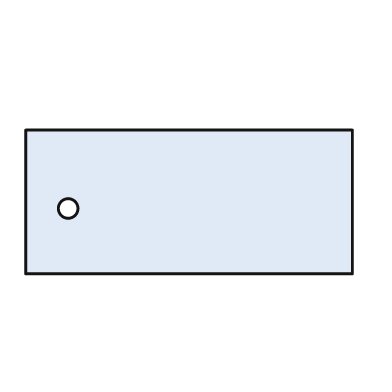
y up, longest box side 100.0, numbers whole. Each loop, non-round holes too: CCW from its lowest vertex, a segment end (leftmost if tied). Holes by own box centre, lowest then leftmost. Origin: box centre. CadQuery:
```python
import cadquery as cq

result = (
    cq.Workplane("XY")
    .moveTo(-50.0, -22.0)
    .lineTo(50.0, -22.0)
    .lineTo(50.0, 22.0)
    .lineTo(-50.0, 22.0)
    .close()
    .moveTo(-37.0, -2.0)
    .circle(3.0)
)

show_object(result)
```